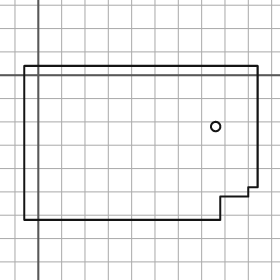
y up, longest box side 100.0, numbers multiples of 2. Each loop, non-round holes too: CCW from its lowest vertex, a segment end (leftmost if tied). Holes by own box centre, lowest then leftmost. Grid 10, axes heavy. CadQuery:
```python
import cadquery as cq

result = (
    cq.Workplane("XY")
    .moveTo(-6.0, -62.0)
    .lineTo(78.0, -62.0)
    .lineTo(78.0, -52.0)
    .lineTo(90.0, -52.0)
    .lineTo(90.0, -48.0)
    .lineTo(94.0, -48.0)
    .lineTo(94.0, 4.0)
    .lineTo(-6.0, 4.0)
    .close()
    .moveTo(76.0, -22.0)
    .circle(2.0)
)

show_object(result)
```